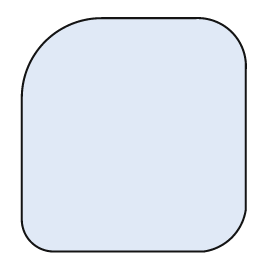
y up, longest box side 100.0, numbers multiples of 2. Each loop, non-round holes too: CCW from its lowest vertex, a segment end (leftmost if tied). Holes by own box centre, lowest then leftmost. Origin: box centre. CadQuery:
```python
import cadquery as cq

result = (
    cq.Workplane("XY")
    .moveTo(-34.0, -50.0)
    .lineTo(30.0, -50.0)
    .threePointArc((42.0, -44.0), (48.0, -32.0))
    .lineTo(48.0, 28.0)
    .threePointArc((42.0, 44.0), (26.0, 50.0))
    .lineTo(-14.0, 50.0)
    .threePointArc((-38.0, 40.0), (-48.0, 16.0))
    .lineTo(-48.0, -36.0)
    .threePointArc((-44.0, -46.0), (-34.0, -50.0))
    .close()
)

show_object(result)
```